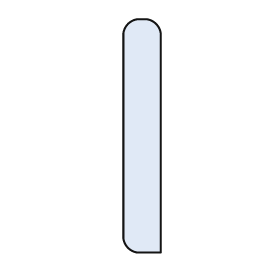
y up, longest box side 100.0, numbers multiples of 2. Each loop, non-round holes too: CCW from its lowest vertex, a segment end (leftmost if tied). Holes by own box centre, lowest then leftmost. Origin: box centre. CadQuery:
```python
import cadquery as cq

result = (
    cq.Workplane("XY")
    .moveTo(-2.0, -50.0)
    .lineTo(8.0, -50.0)
    .lineTo(8.0, 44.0)
    .threePointArc((6.0, 48.0), (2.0, 50.0))
    .lineTo(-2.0, 50.0)
    .threePointArc((-6.0, 48.0), (-8.0, 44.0))
    .lineTo(-8.0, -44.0)
    .threePointArc((-6.0, -48.0), (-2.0, -50.0))
    .close()
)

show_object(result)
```